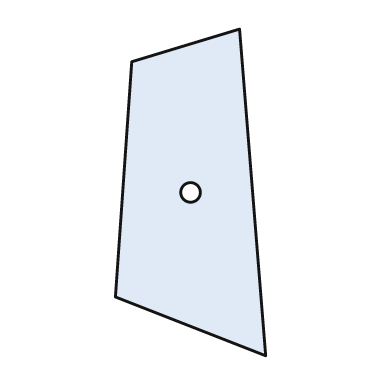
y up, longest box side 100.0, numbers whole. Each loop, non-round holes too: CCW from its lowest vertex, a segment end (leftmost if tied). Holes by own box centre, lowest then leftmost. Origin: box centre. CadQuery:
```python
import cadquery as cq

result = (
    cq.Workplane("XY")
    .moveTo(23.0, -50.0)
    .lineTo(15.0, 50.0)
    .lineTo(-18.0, 40.0)
    .lineTo(-23.0, -32.0)
    .close()
    .moveTo(0.0, 0.0)
    .circle(3.0)
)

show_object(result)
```